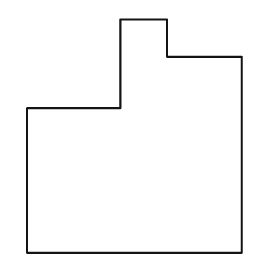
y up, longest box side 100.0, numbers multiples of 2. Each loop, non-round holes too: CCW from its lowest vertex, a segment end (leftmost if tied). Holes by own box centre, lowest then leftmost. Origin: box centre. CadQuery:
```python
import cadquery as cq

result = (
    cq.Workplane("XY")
    .moveTo(-46.0, -50.0)
    .lineTo(46.0, -50.0)
    .lineTo(46.0, 34.0)
    .lineTo(14.0, 34.0)
    .lineTo(14.0, 50.0)
    .lineTo(-6.0, 50.0)
    .lineTo(-6.0, 12.0)
    .lineTo(-46.0, 12.0)
    .close()
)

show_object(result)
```